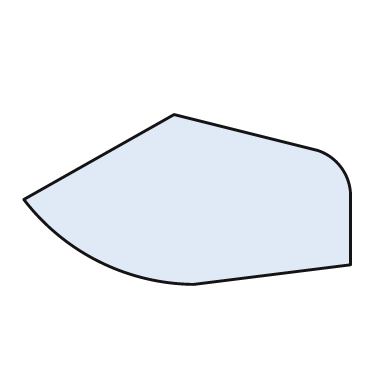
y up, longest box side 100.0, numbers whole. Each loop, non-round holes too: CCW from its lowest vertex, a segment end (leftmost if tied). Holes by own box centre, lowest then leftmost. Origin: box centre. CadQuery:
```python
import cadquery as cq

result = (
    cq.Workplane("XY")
    .moveTo(2.0, -26.0)
    .lineTo(50.0, -20.0)
    .lineTo(50.0, 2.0)
    .threePointArc((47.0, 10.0), (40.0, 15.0))
    .lineTo(-4.0, 26.0)
    .lineTo(-50.0, 0.0)
    .threePointArc((-27.0, -19.0), (2.0, -26.0))
    .close()
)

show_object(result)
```